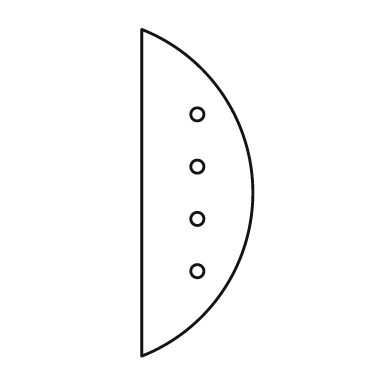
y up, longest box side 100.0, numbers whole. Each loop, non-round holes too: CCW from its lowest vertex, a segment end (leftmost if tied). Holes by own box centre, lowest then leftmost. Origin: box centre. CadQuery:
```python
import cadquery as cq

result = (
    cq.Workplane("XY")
    .moveTo(-17.0, -50.0)
    .threePointArc((17.0, 0.0), (-17.0, 50.0))
    .close()
    .moveTo(0.0, -24.0)
    .circle(2.0)
    .moveTo(0.0, -8.0)
    .circle(2.0)
    .moveTo(0.0, 8.0)
    .circle(2.0)
    .moveTo(0.0, 24.0)
    .circle(2.0)
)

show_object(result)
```